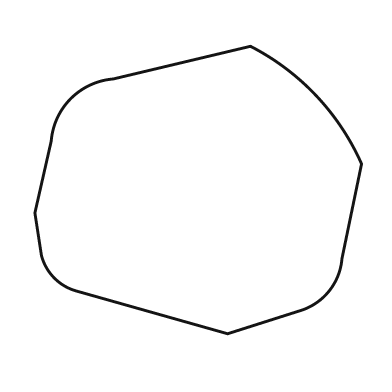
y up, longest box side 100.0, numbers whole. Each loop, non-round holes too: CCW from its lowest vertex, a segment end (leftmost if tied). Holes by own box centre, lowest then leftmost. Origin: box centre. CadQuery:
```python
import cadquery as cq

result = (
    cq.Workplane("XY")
    .moveTo(9.0, -44.0)
    .lineTo(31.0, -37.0)
    .threePointArc((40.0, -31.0), (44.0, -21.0))
    .lineTo(50.0, 8.0)
    .threePointArc((36.0, 29.0), (16.0, 44.0))
    .lineTo(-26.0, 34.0)
    .threePointArc((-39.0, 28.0), (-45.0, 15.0))
    .lineTo(-50.0, -7.0)
    .lineTo(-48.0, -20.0)
    .threePointArc((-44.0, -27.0), (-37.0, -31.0))
    .close()
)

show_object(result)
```